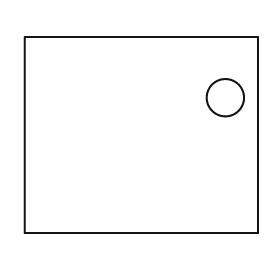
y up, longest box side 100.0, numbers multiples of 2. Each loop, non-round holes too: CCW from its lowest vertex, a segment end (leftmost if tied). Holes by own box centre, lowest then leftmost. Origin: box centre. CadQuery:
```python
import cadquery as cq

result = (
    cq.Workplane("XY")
    .moveTo(-50.0, -42.0)
    .lineTo(50.0, -42.0)
    .lineTo(50.0, 42.0)
    .lineTo(-50.0, 42.0)
    .close()
    .moveTo(36.0, 16.0)
    .circle(8.0)
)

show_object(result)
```